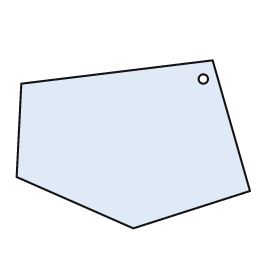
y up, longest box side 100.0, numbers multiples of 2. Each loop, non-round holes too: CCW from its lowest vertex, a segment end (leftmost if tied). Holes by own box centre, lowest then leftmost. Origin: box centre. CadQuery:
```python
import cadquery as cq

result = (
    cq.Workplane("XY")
    .moveTo(0.0, -36.0)
    .lineTo(50.0, -20.0)
    .lineTo(34.0, 36.0)
    .lineTo(-48.0, 26.0)
    .lineTo(-50.0, -14.0)
    .close()
    .moveTo(30.0, 28.0)
    .circle(2.0)
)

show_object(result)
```